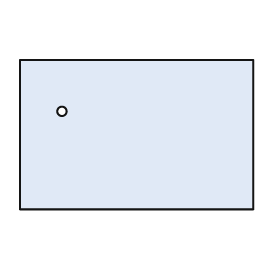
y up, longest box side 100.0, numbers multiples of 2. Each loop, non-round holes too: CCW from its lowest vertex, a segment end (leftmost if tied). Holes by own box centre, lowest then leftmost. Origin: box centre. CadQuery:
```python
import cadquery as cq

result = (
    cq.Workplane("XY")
    .moveTo(-50.0, -32.0)
    .lineTo(50.0, -32.0)
    .lineTo(50.0, 32.0)
    .lineTo(-50.0, 32.0)
    .close()
    .moveTo(-32.0, 10.0)
    .circle(2.0)
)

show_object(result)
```